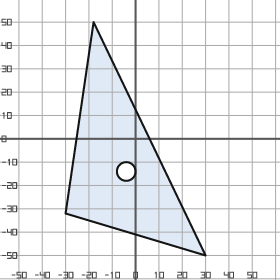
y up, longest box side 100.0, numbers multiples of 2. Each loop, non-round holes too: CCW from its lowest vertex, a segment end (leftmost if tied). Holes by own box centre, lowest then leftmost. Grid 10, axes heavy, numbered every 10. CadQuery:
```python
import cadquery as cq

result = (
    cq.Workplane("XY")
    .moveTo(30.0, -50.0)
    .lineTo(-18.0, 50.0)
    .lineTo(-30.0, -32.0)
    .close()
    .moveTo(-4.0, -14.0)
    .circle(4.0)
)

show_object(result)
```